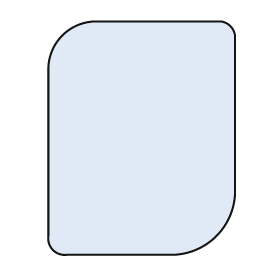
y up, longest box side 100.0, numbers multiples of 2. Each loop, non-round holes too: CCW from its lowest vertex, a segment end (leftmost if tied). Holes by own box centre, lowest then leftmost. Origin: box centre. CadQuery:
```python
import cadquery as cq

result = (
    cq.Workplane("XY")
    .moveTo(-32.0, -50.0)
    .lineTo(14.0, -50.0)
    .threePointArc((32.0, -42.0), (40.0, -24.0))
    .lineTo(40.0, 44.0)
    .threePointArc((38.0, 48.0), (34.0, 50.0))
    .lineTo(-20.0, 50.0)
    .threePointArc((-34.0, 44.0), (-40.0, 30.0))
    .lineTo(-40.0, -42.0)
    .threePointArc((-38.0, -48.0), (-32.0, -50.0))
    .close()
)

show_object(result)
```